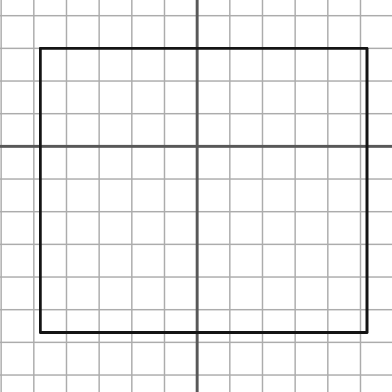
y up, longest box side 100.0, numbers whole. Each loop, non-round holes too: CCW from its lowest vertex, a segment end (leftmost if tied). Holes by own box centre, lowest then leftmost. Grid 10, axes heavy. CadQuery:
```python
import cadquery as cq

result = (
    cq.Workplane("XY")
    .moveTo(-48.0, -57.0)
    .lineTo(52.0, -57.0)
    .lineTo(52.0, 30.0)
    .lineTo(-48.0, 30.0)
    .close()
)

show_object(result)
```